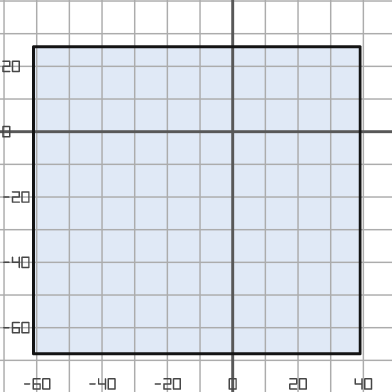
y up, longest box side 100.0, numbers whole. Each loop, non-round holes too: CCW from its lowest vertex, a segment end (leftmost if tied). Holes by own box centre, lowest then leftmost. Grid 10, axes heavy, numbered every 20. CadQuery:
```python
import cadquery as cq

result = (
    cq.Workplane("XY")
    .moveTo(-61.0, -68.0)
    .lineTo(39.0, -68.0)
    .lineTo(39.0, 26.0)
    .lineTo(-61.0, 26.0)
    .close()
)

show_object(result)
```